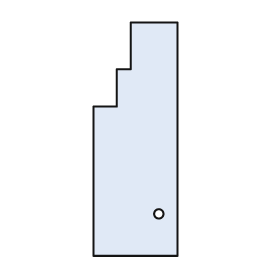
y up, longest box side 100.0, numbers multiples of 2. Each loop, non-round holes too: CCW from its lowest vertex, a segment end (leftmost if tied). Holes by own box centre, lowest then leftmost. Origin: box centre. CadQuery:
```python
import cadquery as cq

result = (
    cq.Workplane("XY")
    .moveTo(-18.0, -50.0)
    .lineTo(18.0, -50.0)
    .lineTo(18.0, 50.0)
    .lineTo(-2.0, 50.0)
    .lineTo(-2.0, 30.0)
    .lineTo(-8.0, 30.0)
    .lineTo(-8.0, 14.0)
    .lineTo(-18.0, 14.0)
    .close()
    .moveTo(10.0, -32.0)
    .circle(2.0)
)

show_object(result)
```